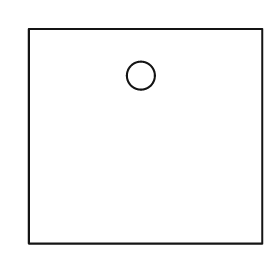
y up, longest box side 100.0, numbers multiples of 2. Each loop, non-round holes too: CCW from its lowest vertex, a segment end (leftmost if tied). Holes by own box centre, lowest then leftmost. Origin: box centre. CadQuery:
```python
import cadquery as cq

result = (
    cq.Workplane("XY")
    .moveTo(-50.0, -46.0)
    .lineTo(50.0, -46.0)
    .lineTo(50.0, 46.0)
    .lineTo(-50.0, 46.0)
    .close()
    .moveTo(-2.0, 26.0)
    .circle(6.0)
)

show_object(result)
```